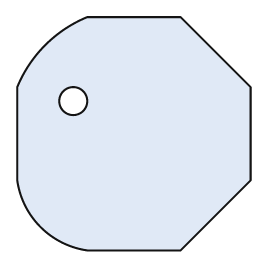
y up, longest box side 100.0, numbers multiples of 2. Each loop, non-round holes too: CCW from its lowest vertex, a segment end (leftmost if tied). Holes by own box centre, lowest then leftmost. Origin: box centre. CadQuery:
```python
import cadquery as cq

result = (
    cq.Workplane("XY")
    .moveTo(-20.0, -50.0)
    .lineTo(20.0, -50.0)
    .lineTo(50.0, -20.0)
    .lineTo(50.0, 20.0)
    .lineTo(20.0, 50.0)
    .lineTo(-20.0, 50.0)
    .threePointArc((-38.0, 38.0), (-50.0, 20.0))
    .lineTo(-50.0, -20.0)
    .threePointArc((-40.0, -40.0), (-20.0, -50.0))
    .close()
    .moveTo(-26.0, 14.0)
    .circle(6.0)
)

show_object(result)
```